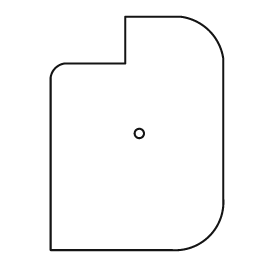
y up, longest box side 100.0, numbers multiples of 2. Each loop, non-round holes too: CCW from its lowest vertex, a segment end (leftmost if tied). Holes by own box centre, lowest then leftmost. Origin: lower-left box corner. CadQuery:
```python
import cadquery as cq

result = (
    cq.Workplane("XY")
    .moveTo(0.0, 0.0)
    .lineTo(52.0, 0.0)
    .threePointArc((68.0, 6.0), (74.0, 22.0))
    .lineTo(74.0, 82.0)
    .threePointArc((68.0, 94.0), (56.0, 100.0))
    .lineTo(32.0, 100.0)
    .lineTo(32.0, 80.0)
    .lineTo(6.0, 80.0)
    .threePointArc((2.0, 78.0), (0.0, 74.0))
    .close()
    .moveTo(38.0, 50.0)
    .circle(2.0)
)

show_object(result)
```